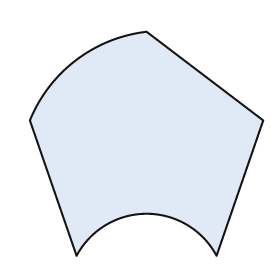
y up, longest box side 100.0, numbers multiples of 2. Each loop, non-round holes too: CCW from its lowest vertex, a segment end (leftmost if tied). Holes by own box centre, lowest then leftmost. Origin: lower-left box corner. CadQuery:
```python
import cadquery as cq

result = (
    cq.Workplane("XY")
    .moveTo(20.0, 0.0)
    .threePointArc((50.0, 18.0), (80.0, 0.0))
    .lineTo(100.0, 58.0)
    .lineTo(50.0, 96.0)
    .threePointArc((20.0, 84.0), (0.0, 58.0))
    .close()
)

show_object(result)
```